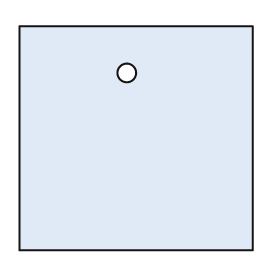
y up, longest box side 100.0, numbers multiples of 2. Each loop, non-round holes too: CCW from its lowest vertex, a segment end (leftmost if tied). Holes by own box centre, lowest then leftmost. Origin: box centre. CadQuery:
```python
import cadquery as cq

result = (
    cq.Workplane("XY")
    .moveTo(-50.0, -48.0)
    .lineTo(50.0, -48.0)
    .lineTo(50.0, 48.0)
    .lineTo(-50.0, 48.0)
    .close()
    .moveTo(-4.0, 28.0)
    .circle(4.0)
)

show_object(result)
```